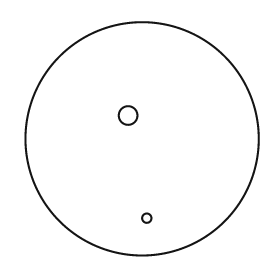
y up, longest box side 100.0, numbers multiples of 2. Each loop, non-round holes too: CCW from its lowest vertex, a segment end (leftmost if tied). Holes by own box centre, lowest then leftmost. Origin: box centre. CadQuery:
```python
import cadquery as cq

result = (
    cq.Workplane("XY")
    .moveTo(0.0, 0.0)
    .circle(50.0)
    .moveTo(2.0, -34.0)
    .circle(2.0)
    .moveTo(-6.0, 10.0)
    .circle(4.0)
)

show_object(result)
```